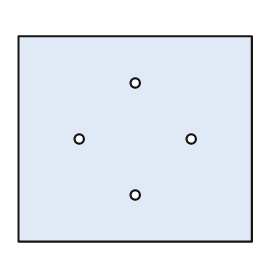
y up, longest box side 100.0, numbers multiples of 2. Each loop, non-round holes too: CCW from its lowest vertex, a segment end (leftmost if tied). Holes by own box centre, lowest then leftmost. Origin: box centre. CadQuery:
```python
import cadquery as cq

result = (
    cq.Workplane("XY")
    .moveTo(-50.0, -44.0)
    .lineTo(50.0, -44.0)
    .lineTo(50.0, 44.0)
    .lineTo(-50.0, 44.0)
    .close()
    .moveTo(0.0, -24.0)
    .circle(2.0)
    .moveTo(-24.0, 0.0)
    .circle(2.0)
    .moveTo(24.0, 0.0)
    .circle(2.0)
    .moveTo(0.0, 24.0)
    .circle(2.0)
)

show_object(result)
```